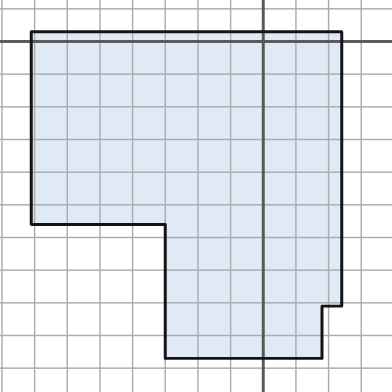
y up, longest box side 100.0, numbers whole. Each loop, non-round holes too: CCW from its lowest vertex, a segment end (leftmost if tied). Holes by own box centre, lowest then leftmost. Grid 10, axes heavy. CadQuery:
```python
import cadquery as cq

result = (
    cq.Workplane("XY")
    .moveTo(-30.0, -97.0)
    .lineTo(18.0, -97.0)
    .lineTo(18.0, -81.0)
    .lineTo(24.0, -81.0)
    .lineTo(24.0, 3.0)
    .lineTo(-71.0, 3.0)
    .lineTo(-71.0, -56.0)
    .lineTo(-30.0, -56.0)
    .close()
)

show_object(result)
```